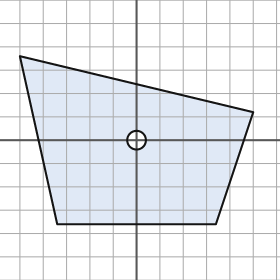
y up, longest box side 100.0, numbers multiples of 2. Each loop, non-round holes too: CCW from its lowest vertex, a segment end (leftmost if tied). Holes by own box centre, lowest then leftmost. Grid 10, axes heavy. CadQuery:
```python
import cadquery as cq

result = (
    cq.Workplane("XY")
    .moveTo(-34.0, -36.0)
    .lineTo(34.0, -36.0)
    .lineTo(50.0, 12.0)
    .lineTo(-50.0, 36.0)
    .close()
    .moveTo(0.0, 0.0)
    .circle(4.0)
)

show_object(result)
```